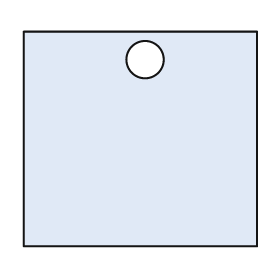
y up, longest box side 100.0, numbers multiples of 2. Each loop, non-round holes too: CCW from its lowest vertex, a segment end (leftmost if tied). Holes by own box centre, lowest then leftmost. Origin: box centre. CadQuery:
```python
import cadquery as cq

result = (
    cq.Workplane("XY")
    .moveTo(-50.0, -46.0)
    .lineTo(50.0, -46.0)
    .lineTo(50.0, 46.0)
    .lineTo(-50.0, 46.0)
    .close()
    .moveTo(2.0, 34.0)
    .circle(8.0)
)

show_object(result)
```